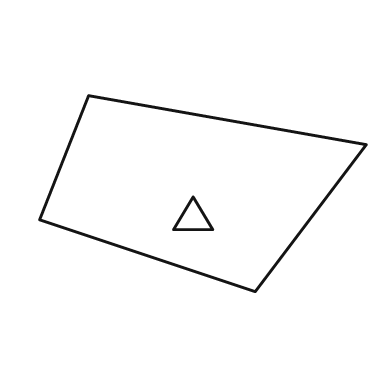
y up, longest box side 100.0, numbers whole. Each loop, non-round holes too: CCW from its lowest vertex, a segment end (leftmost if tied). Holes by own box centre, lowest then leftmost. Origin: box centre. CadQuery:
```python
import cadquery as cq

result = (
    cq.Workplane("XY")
    .moveTo(16.0, -30.0)
    .lineTo(50.0, 15.0)
    .lineTo(-35.0, 30.0)
    .lineTo(-50.0, -8.0)
    .close()
    .moveTo(-9.0, -11.0)
    .lineTo(3.0, -11.0)
    .lineTo(-3.0, -1.0)
    .close()
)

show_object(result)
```